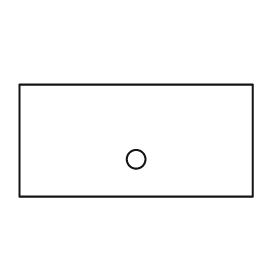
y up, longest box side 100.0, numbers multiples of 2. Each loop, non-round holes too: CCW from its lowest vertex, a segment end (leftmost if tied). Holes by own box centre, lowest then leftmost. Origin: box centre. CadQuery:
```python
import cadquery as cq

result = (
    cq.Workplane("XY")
    .moveTo(-50.0, -24.0)
    .lineTo(50.0, -24.0)
    .lineTo(50.0, 24.0)
    .lineTo(-50.0, 24.0)
    .close()
    .moveTo(0.0, -8.0)
    .circle(4.0)
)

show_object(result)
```